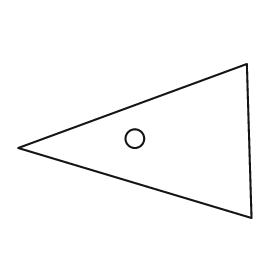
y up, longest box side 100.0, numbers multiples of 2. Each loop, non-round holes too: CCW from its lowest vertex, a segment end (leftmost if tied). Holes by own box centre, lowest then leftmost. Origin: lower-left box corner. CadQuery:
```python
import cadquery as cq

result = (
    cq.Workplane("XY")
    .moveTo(100.0, 0.0)
    .lineTo(98.0, 66.0)
    .lineTo(0.0, 30.0)
    .close()
    .moveTo(50.0, 34.0)
    .circle(4.0)
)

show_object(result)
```